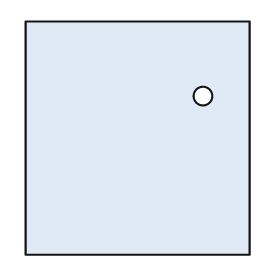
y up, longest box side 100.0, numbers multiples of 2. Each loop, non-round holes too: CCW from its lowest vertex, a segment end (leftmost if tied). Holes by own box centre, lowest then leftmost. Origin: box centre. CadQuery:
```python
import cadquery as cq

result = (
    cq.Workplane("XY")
    .moveTo(-48.0, -50.0)
    .lineTo(48.0, -50.0)
    .lineTo(48.0, 50.0)
    .lineTo(-48.0, 50.0)
    .close()
    .moveTo(28.0, 18.0)
    .circle(4.0)
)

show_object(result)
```